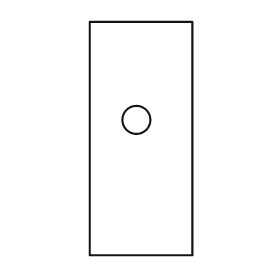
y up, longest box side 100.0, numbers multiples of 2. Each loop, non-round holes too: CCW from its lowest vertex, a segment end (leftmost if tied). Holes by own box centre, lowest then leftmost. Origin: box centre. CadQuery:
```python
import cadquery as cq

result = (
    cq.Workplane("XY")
    .moveTo(-22.0, -50.0)
    .lineTo(22.0, -50.0)
    .lineTo(22.0, 50.0)
    .lineTo(-22.0, 50.0)
    .close()
    .moveTo(-2.0, 8.0)
    .circle(6.0)
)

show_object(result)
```